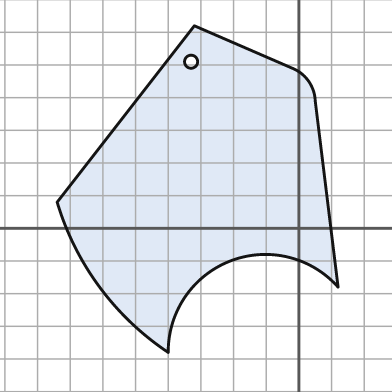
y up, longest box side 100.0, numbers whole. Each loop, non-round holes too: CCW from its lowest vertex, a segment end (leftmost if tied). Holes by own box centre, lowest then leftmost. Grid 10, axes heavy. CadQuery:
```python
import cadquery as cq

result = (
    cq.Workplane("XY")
    .moveTo(-40.0, -38.0)
    .threePointArc((-21.0, -10.0), (12.0, -18.0))
    .lineTo(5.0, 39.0)
    .threePointArc((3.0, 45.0), (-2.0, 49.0))
    .lineTo(-32.0, 62.0)
    .lineTo(-74.0, 8.0)
    .threePointArc((-61.0, -18.0), (-40.0, -38.0))
    .close()
    .moveTo(-33.0, 51.0)
    .circle(2.0)
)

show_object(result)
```